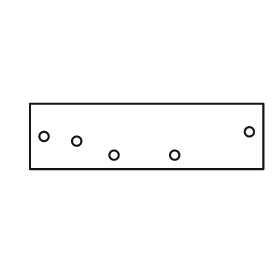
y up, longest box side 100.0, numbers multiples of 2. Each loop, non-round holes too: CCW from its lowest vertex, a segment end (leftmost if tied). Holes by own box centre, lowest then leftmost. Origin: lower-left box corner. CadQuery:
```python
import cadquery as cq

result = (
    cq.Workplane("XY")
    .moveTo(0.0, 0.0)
    .lineTo(100.0, 0.0)
    .lineTo(100.0, 28.0)
    .lineTo(0.0, 28.0)
    .close()
    .moveTo(36.0, 6.0)
    .circle(2.0)
    .moveTo(62.0, 6.0)
    .circle(2.0)
    .moveTo(20.0, 12.0)
    .circle(2.0)
    .moveTo(6.0, 14.0)
    .circle(2.0)
    .moveTo(94.0, 16.0)
    .circle(2.0)
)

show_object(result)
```